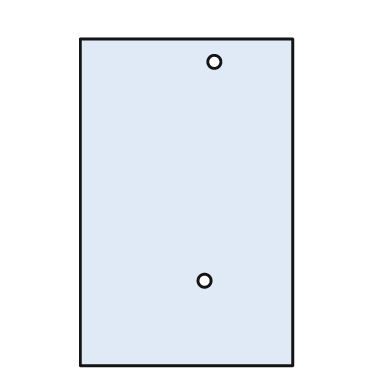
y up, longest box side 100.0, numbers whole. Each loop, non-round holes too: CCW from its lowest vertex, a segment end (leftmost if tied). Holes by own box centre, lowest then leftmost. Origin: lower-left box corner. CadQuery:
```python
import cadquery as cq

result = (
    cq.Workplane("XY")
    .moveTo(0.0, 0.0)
    .lineTo(65.0, 0.0)
    .lineTo(65.0, 100.0)
    .lineTo(0.0, 100.0)
    .close()
    .moveTo(38.0, 26.0)
    .circle(2.0)
    .moveTo(41.0, 93.0)
    .circle(2.0)
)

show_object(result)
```